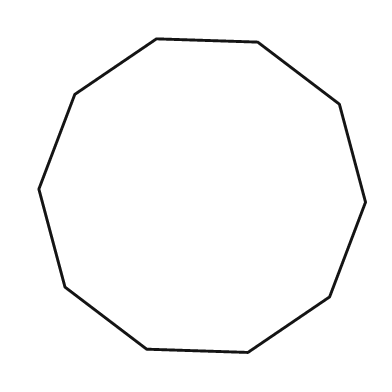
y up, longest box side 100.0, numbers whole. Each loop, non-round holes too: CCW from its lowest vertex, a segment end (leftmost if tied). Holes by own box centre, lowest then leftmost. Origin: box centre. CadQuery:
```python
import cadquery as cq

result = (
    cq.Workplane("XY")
    .moveTo(14.0, -48.0)
    .lineTo(39.0, -31.0)
    .lineTo(50.0, -2.0)
    .lineTo(42.0, 28.0)
    .lineTo(17.0, 47.0)
    .lineTo(-14.0, 48.0)
    .lineTo(-39.0, 31.0)
    .lineTo(-50.0, 2.0)
    .lineTo(-42.0, -28.0)
    .lineTo(-17.0, -47.0)
    .close()
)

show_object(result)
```